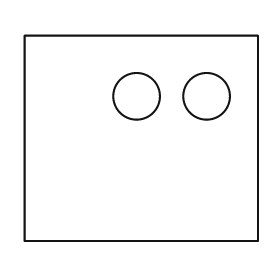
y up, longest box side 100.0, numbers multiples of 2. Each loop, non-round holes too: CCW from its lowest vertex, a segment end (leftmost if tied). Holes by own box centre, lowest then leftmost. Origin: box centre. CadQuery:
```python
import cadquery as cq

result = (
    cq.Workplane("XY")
    .moveTo(-50.0, -44.0)
    .lineTo(50.0, -44.0)
    .lineTo(50.0, 44.0)
    .lineTo(-50.0, 44.0)
    .close()
    .moveTo(-2.0, 18.0)
    .circle(10.0)
    .moveTo(28.0, 18.0)
    .circle(10.0)
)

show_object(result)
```